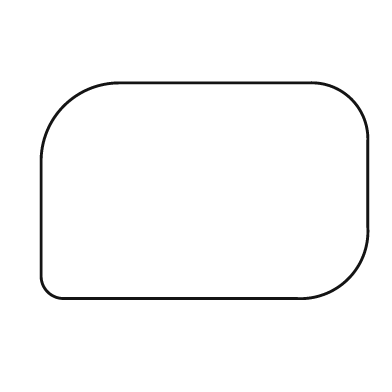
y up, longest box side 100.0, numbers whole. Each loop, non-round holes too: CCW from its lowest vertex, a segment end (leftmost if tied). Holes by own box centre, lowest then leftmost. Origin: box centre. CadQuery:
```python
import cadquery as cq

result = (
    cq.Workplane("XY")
    .moveTo(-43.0, -33.0)
    .lineTo(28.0, -33.0)
    .threePointArc((44.0, -27.0), (50.0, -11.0))
    .lineTo(50.0, 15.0)
    .threePointArc((45.0, 28.0), (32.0, 33.0))
    .lineTo(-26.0, 33.0)
    .threePointArc((-43.0, 26.0), (-50.0, 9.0))
    .lineTo(-50.0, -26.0)
    .threePointArc((-48.0, -31.0), (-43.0, -33.0))
    .close()
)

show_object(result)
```